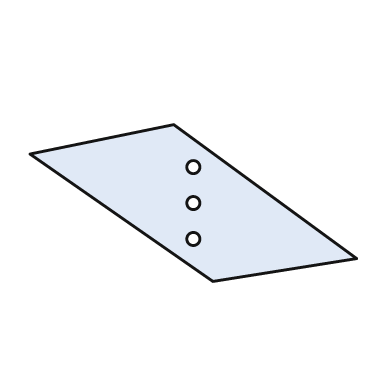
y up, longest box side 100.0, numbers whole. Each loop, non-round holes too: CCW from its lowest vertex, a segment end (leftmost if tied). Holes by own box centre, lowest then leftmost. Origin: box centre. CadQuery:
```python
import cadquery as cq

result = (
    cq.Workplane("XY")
    .moveTo(6.0, -24.0)
    .lineTo(50.0, -17.0)
    .lineTo(-6.0, 24.0)
    .lineTo(-50.0, 15.0)
    .close()
    .moveTo(0.0, -11.0)
    .circle(2.0)
    .moveTo(0.0, 0.0)
    .circle(2.0)
    .moveTo(0.0, 11.0)
    .circle(2.0)
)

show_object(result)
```